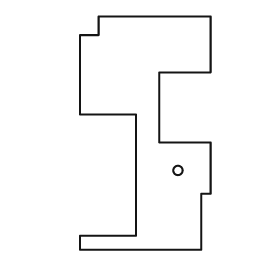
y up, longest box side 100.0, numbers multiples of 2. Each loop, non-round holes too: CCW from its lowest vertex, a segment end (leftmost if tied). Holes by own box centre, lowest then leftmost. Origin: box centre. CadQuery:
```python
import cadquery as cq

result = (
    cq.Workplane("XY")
    .moveTo(-28.0, -50.0)
    .lineTo(24.0, -50.0)
    .lineTo(24.0, -26.0)
    .lineTo(28.0, -26.0)
    .lineTo(28.0, -4.0)
    .lineTo(6.0, -4.0)
    .lineTo(6.0, 26.0)
    .lineTo(28.0, 26.0)
    .lineTo(28.0, 50.0)
    .lineTo(-20.0, 50.0)
    .lineTo(-20.0, 42.0)
    .lineTo(-28.0, 42.0)
    .lineTo(-28.0, 8.0)
    .lineTo(-4.0, 8.0)
    .lineTo(-4.0, -44.0)
    .lineTo(-28.0, -44.0)
    .close()
    .moveTo(14.0, -16.0)
    .circle(2.0)
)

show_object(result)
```